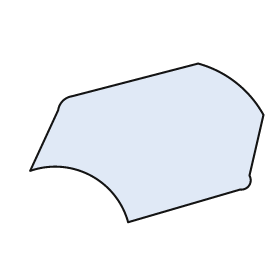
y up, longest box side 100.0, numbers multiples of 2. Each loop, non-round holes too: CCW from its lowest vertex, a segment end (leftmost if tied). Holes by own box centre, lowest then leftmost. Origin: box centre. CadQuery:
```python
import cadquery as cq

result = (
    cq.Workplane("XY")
    .moveTo(-8.0, -34.0)
    .lineTo(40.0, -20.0)
    .threePointArc((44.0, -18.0), (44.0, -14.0))
    .lineTo(50.0, 12.0)
    .threePointArc((38.0, 26.0), (22.0, 34.0))
    .lineTo(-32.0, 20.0)
    .threePointArc((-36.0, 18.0), (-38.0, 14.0))
    .lineTo(-50.0, -12.0)
    .threePointArc((-24.0, -14.0), (-8.0, -34.0))
    .close()
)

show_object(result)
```